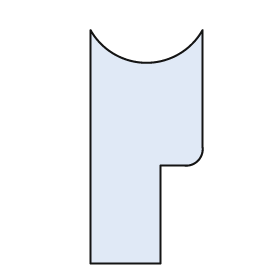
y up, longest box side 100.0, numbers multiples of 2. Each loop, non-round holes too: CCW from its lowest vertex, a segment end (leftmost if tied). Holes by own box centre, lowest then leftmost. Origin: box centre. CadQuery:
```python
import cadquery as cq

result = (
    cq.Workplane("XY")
    .moveTo(-24.0, -50.0)
    .lineTo(6.0, -50.0)
    .lineTo(6.0, -8.0)
    .lineTo(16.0, -8.0)
    .threePointArc((22.0, -6.0), (24.0, 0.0))
    .lineTo(24.0, 50.0)
    .threePointArc((0.0, 36.0), (-24.0, 50.0))
    .close()
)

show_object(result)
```